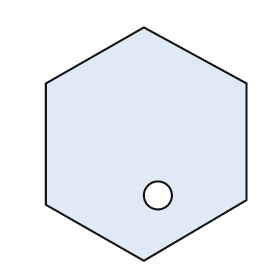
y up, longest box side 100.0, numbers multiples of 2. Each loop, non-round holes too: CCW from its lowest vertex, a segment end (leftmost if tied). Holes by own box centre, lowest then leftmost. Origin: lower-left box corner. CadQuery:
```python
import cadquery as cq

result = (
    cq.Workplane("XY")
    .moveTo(42.0, 0.0)
    .lineTo(86.0, 26.0)
    .lineTo(86.0, 76.0)
    .lineTo(42.0, 100.0)
    .lineTo(0.0, 76.0)
    .lineTo(0.0, 24.0)
    .close()
    .moveTo(48.0, 28.0)
    .circle(6.0)
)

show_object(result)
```